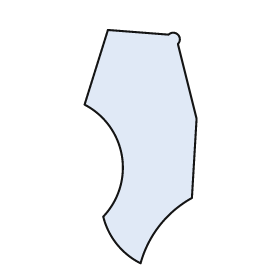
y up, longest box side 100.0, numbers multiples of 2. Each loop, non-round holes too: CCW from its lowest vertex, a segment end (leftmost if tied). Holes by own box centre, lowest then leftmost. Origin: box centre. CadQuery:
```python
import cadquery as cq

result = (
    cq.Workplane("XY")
    .moveTo(0.0, -50.0)
    .threePointArc((8.0, -34.0), (22.0, -22.0))
    .lineTo(24.0, 12.0)
    .lineTo(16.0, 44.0)
    .threePointArc((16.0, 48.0), (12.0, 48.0))
    .lineTo(-14.0, 50.0)
    .lineTo(-24.0, 18.0)
    .threePointArc((-8.0, -4.0), (-16.0, -30.0))
    .threePointArc((-10.0, -42.0), (0.0, -50.0))
    .close()
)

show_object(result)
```